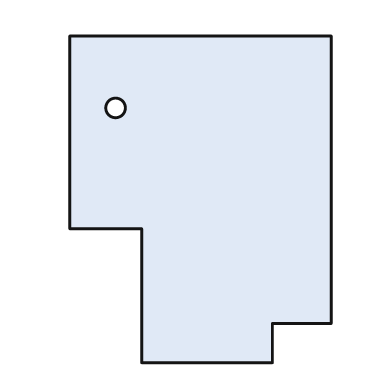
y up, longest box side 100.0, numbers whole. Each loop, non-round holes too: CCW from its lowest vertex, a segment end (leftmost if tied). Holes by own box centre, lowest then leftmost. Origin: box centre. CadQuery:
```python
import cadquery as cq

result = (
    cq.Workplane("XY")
    .moveTo(-18.0, -50.0)
    .lineTo(22.0, -50.0)
    .lineTo(22.0, -38.0)
    .lineTo(40.0, -38.0)
    .lineTo(40.0, 50.0)
    .lineTo(-40.0, 50.0)
    .lineTo(-40.0, -9.0)
    .lineTo(-18.0, -9.0)
    .close()
    .moveTo(-26.0, 28.0)
    .circle(3.0)
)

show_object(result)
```